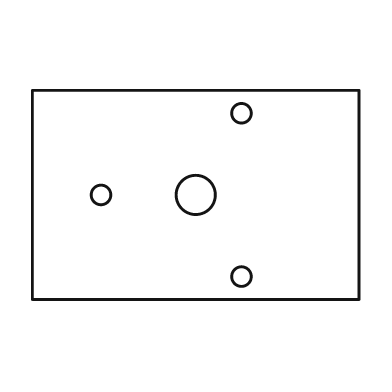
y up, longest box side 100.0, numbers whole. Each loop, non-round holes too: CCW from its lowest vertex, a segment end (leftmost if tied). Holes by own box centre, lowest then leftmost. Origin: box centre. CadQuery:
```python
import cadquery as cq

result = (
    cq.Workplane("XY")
    .moveTo(-50.0, -32.0)
    .lineTo(50.0, -32.0)
    .lineTo(50.0, 32.0)
    .lineTo(-50.0, 32.0)
    .close()
    .moveTo(14.0, -25.0)
    .circle(3.0)
    .moveTo(-29.0, 0.0)
    .circle(3.0)
    .moveTo(0.0, 0.0)
    .circle(6.0)
    .moveTo(14.0, 25.0)
    .circle(3.0)
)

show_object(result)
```